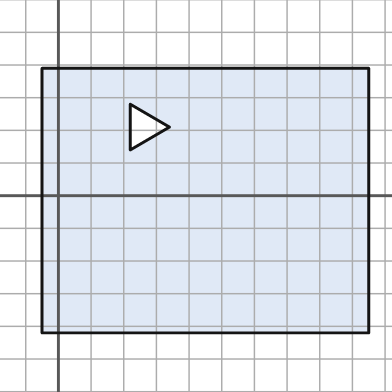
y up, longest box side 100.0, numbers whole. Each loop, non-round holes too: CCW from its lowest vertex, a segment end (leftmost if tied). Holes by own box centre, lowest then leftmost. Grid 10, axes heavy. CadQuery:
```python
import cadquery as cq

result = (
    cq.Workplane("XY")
    .moveTo(-5.0, -42.0)
    .lineTo(95.0, -42.0)
    .lineTo(95.0, 39.0)
    .lineTo(-5.0, 39.0)
    .close()
    .moveTo(22.0, 14.0)
    .lineTo(34.0, 21.0)
    .lineTo(22.0, 28.0)
    .close()
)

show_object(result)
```